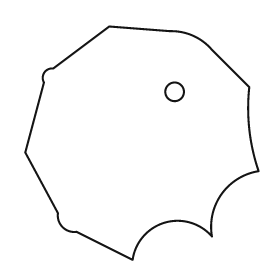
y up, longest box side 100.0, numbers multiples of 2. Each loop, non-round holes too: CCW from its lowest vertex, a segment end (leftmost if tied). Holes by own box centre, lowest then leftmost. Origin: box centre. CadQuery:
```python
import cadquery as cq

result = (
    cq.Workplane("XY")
    .moveTo(-4.0, -50.0)
    .threePointArc((10.0, -34.0), (30.0, -40.0))
    .threePointArc((34.0, -22.0), (50.0, -12.0))
    .threePointArc((46.0, 6.0), (46.0, 24.0))
    .lineTo(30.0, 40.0)
    .threePointArc((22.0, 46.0), (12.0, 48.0))
    .lineTo(-14.0, 50.0)
    .lineTo(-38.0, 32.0)
    .threePointArc((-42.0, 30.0), (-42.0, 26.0))
    .lineTo(-50.0, -4.0)
    .lineTo(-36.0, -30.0)
    .threePointArc((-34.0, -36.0), (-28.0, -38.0))
    .close()
    .moveTo(14.0, 22.0)
    .circle(4.0)
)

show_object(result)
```